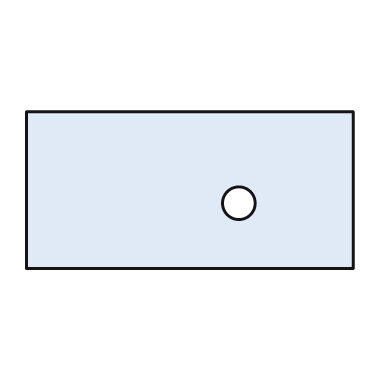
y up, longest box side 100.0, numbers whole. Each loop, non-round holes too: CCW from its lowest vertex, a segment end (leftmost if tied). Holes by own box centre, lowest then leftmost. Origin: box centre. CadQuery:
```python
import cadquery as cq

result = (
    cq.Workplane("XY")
    .moveTo(-50.0, -24.0)
    .lineTo(50.0, -24.0)
    .lineTo(50.0, 24.0)
    .lineTo(-50.0, 24.0)
    .close()
    .moveTo(15.0, -4.0)
    .circle(5.0)
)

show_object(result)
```